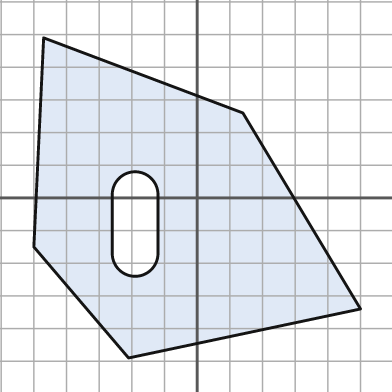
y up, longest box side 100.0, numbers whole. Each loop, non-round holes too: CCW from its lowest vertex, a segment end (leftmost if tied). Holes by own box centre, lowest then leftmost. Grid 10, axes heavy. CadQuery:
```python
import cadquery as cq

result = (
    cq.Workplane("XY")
    .moveTo(-21.0, -49.0)
    .lineTo(50.0, -34.0)
    .lineTo(14.0, 26.0)
    .lineTo(-47.0, 49.0)
    .lineTo(-50.0, -15.0)
    .close()
    .moveTo(-26.0, -17.0)
    .threePointArc((-19.0, -24.0), (-12.0, -17.0))
    .lineTo(-12.0, 1.0)
    .threePointArc((-19.0, 8.0), (-26.0, 1.0))
    .close()
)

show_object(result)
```